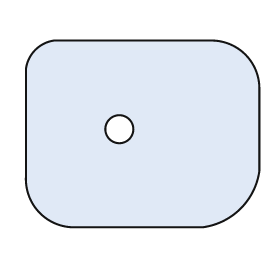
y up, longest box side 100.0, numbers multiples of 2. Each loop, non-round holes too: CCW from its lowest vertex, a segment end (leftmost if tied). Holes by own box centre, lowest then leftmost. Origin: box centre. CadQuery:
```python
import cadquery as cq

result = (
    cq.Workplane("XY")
    .moveTo(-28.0, -40.0)
    .lineTo(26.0, -40.0)
    .threePointArc((42.0, -32.0), (50.0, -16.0))
    .lineTo(50.0, 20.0)
    .threePointArc((44.0, 34.0), (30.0, 40.0))
    .lineTo(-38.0, 40.0)
    .threePointArc((-46.0, 36.0), (-50.0, 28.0))
    .lineTo(-50.0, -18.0)
    .threePointArc((-44.0, -34.0), (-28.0, -40.0))
    .close()
    .moveTo(-10.0, 2.0)
    .circle(6.0)
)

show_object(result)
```